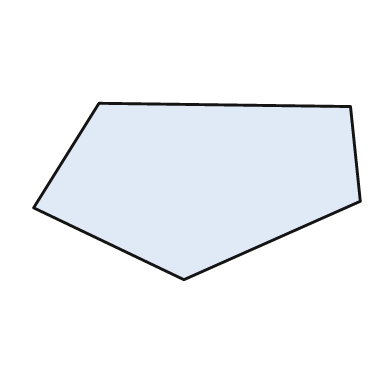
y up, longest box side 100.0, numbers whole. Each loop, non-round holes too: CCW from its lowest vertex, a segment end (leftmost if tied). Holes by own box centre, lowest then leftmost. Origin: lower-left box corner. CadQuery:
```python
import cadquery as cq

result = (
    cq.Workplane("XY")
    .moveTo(46.0, 0.0)
    .lineTo(100.0, 24.0)
    .lineTo(97.0, 53.0)
    .lineTo(20.0, 54.0)
    .lineTo(0.0, 22.0)
    .close()
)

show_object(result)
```